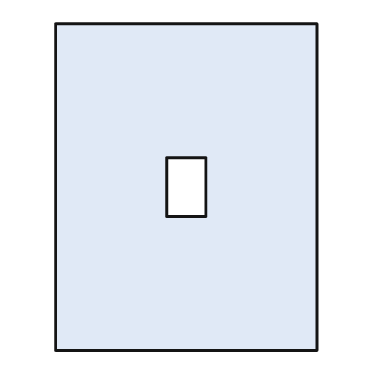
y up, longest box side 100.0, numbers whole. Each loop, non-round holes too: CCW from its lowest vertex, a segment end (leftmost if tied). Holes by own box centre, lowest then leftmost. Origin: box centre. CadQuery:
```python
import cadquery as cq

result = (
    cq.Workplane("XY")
    .moveTo(-40.0, -50.0)
    .lineTo(40.0, -50.0)
    .lineTo(40.0, 50.0)
    .lineTo(-40.0, 50.0)
    .close()
    .moveTo(-6.0, -9.0)
    .lineTo(6.0, -9.0)
    .lineTo(6.0, 9.0)
    .lineTo(-6.0, 9.0)
    .close()
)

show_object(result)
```